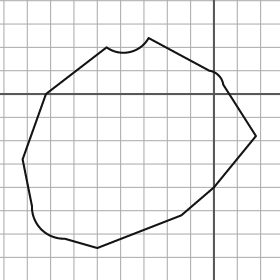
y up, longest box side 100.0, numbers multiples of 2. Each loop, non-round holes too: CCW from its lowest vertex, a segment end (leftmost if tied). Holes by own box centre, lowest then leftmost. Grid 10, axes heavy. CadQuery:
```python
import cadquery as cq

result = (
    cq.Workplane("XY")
    .moveTo(-50.0, -66.0)
    .lineTo(-14.0, -52.0)
    .lineTo(0.0, -40.0)
    .lineTo(18.0, -18.0)
    .lineTo(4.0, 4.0)
    .threePointArc((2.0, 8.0), (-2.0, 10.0))
    .lineTo(-28.0, 24.0)
    .threePointArc((-36.0, 18.0), (-46.0, 20.0))
    .lineTo(-72.0, 0.0)
    .lineTo(-82.0, -28.0)
    .lineTo(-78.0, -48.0)
    .threePointArc((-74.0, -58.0), (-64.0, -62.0))
    .close()
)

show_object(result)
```